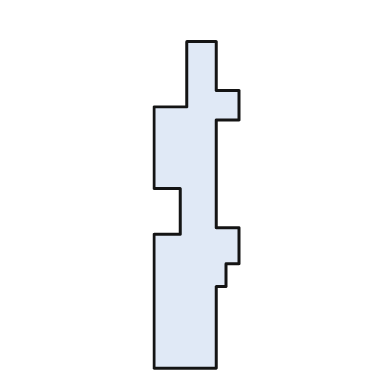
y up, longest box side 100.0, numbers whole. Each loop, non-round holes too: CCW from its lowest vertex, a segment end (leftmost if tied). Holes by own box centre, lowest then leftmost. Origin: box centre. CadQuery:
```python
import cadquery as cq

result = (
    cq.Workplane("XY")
    .moveTo(-13.0, -50.0)
    .lineTo(6.0, -50.0)
    .lineTo(6.0, -25.0)
    .lineTo(9.0, -25.0)
    .lineTo(9.0, -18.0)
    .lineTo(13.0, -18.0)
    .lineTo(13.0, -7.0)
    .lineTo(6.0, -7.0)
    .lineTo(6.0, 26.0)
    .lineTo(13.0, 26.0)
    .lineTo(13.0, 35.0)
    .lineTo(6.0, 35.0)
    .lineTo(6.0, 50.0)
    .lineTo(-3.0, 50.0)
    .lineTo(-3.0, 30.0)
    .lineTo(-13.0, 30.0)
    .lineTo(-13.0, 5.0)
    .lineTo(-5.0, 5.0)
    .lineTo(-5.0, -9.0)
    .lineTo(-13.0, -9.0)
    .close()
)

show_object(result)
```